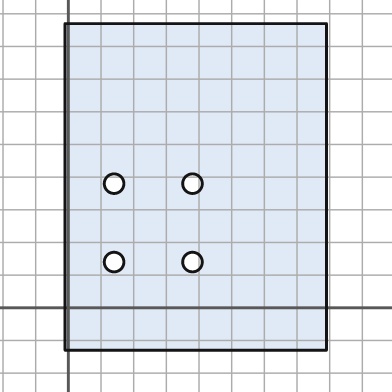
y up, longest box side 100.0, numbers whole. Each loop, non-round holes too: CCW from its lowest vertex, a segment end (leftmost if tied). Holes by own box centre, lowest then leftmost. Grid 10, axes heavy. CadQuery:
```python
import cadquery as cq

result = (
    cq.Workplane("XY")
    .moveTo(-1.0, -13.0)
    .lineTo(79.0, -13.0)
    .lineTo(79.0, 87.0)
    .lineTo(-1.0, 87.0)
    .close()
    .moveTo(14.0, 14.0)
    .circle(3.0)
    .moveTo(38.0, 14.0)
    .circle(3.0)
    .moveTo(14.0, 38.0)
    .circle(3.0)
    .moveTo(38.0, 38.0)
    .circle(3.0)
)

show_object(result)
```